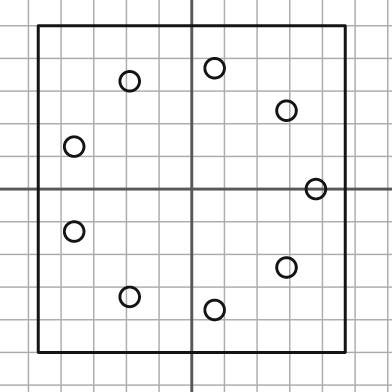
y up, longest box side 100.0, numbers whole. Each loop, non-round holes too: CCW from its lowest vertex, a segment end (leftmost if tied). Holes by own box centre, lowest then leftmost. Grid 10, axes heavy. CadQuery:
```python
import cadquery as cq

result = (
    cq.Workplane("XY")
    .moveTo(-47.0, -50.0)
    .lineTo(47.0, -50.0)
    .lineTo(47.0, 50.0)
    .lineTo(-47.0, 50.0)
    .close()
    .moveTo(7.0, -37.0)
    .circle(3.0)
    .moveTo(-19.0, -33.0)
    .circle(3.0)
    .moveTo(29.0, -24.0)
    .circle(3.0)
    .moveTo(-36.0, -13.0)
    .circle(3.0)
    .moveTo(38.0, 0.0)
    .circle(3.0)
    .moveTo(-36.0, 13.0)
    .circle(3.0)
    .moveTo(29.0, 24.0)
    .circle(3.0)
    .moveTo(-19.0, 33.0)
    .circle(3.0)
    .moveTo(7.0, 37.0)
    .circle(3.0)
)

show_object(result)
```